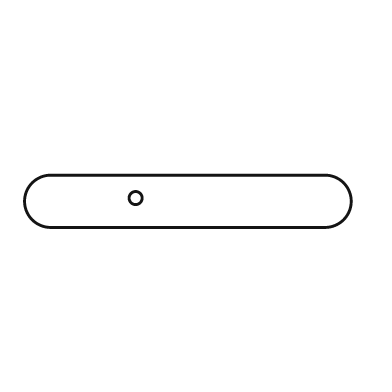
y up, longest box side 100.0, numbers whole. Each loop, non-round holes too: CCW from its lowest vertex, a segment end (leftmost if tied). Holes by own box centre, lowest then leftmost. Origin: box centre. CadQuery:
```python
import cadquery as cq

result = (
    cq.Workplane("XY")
    .moveTo(-42.0, -8.0)
    .lineTo(42.0, -8.0)
    .threePointArc((50.0, 0.0), (42.0, 8.0))
    .lineTo(-42.0, 8.0)
    .threePointArc((-50.0, 0.0), (-42.0, -8.0))
    .close()
    .moveTo(-16.0, 1.0)
    .circle(2.0)
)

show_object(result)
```